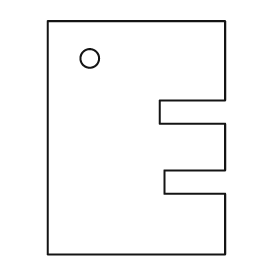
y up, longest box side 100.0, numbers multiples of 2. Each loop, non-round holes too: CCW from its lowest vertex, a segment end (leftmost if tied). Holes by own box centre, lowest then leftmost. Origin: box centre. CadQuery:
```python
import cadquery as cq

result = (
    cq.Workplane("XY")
    .moveTo(-38.0, -50.0)
    .lineTo(38.0, -50.0)
    .lineTo(38.0, -24.0)
    .lineTo(12.0, -24.0)
    .lineTo(12.0, -14.0)
    .lineTo(38.0, -14.0)
    .lineTo(38.0, 6.0)
    .lineTo(10.0, 6.0)
    .lineTo(10.0, 16.0)
    .lineTo(38.0, 16.0)
    .lineTo(38.0, 50.0)
    .lineTo(-38.0, 50.0)
    .close()
    .moveTo(-20.0, 34.0)
    .circle(4.0)
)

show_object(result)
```